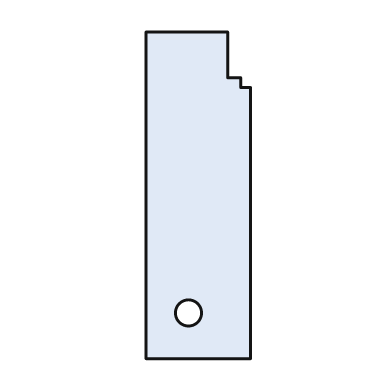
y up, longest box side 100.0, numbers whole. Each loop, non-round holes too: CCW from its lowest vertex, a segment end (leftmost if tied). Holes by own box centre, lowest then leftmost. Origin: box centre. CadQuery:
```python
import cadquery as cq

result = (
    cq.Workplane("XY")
    .moveTo(-16.0, -50.0)
    .lineTo(16.0, -50.0)
    .lineTo(16.0, 33.0)
    .lineTo(13.0, 33.0)
    .lineTo(13.0, 36.0)
    .lineTo(9.0, 36.0)
    .lineTo(9.0, 50.0)
    .lineTo(-16.0, 50.0)
    .close()
    .moveTo(-3.0, -36.0)
    .circle(4.0)
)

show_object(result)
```